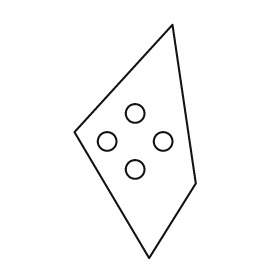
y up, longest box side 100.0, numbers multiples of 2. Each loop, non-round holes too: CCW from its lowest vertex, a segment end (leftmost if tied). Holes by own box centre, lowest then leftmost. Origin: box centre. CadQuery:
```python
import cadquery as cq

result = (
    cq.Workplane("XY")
    .moveTo(6.0, -50.0)
    .lineTo(26.0, -18.0)
    .lineTo(16.0, 50.0)
    .lineTo(-26.0, 4.0)
    .close()
    .moveTo(0.0, -12.0)
    .circle(4.0)
    .moveTo(-12.0, 0.0)
    .circle(4.0)
    .moveTo(12.0, 0.0)
    .circle(4.0)
    .moveTo(0.0, 12.0)
    .circle(4.0)
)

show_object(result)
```